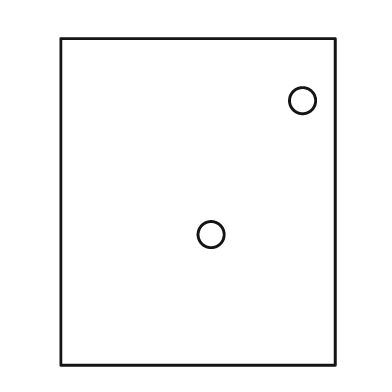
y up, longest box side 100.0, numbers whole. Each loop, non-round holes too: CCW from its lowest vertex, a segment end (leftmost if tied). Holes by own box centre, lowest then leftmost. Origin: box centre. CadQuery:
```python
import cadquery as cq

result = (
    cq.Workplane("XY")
    .moveTo(-42.0, -50.0)
    .lineTo(42.0, -50.0)
    .lineTo(42.0, 50.0)
    .lineTo(-42.0, 50.0)
    .close()
    .moveTo(4.0, -10.0)
    .circle(4.0)
    .moveTo(32.0, 31.0)
    .circle(4.0)
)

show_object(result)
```